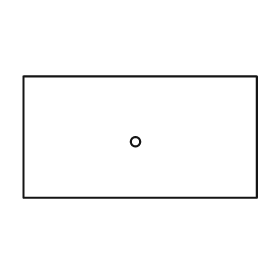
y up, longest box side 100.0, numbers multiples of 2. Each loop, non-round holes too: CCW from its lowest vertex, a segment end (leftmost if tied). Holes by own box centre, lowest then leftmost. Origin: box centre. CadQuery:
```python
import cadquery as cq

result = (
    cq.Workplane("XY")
    .moveTo(-50.0, -26.0)
    .lineTo(50.0, -26.0)
    .lineTo(50.0, 26.0)
    .lineTo(-50.0, 26.0)
    .close()
    .moveTo(-2.0, -2.0)
    .circle(2.0)
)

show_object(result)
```